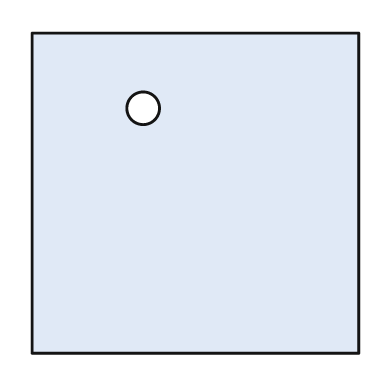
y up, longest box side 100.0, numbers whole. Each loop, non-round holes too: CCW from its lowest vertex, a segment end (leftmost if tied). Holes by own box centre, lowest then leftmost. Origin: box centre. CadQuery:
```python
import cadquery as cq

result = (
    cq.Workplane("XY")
    .moveTo(-50.0, -49.0)
    .lineTo(50.0, -49.0)
    .lineTo(50.0, 49.0)
    .lineTo(-50.0, 49.0)
    .close()
    .moveTo(-16.0, 26.0)
    .circle(5.0)
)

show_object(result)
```